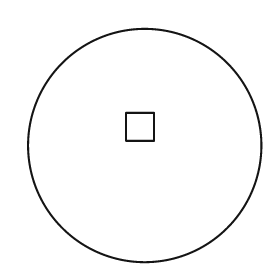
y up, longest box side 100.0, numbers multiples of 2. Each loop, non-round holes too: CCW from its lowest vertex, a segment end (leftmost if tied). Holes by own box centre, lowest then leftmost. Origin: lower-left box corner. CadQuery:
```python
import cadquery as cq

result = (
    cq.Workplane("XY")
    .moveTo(50.0, 50.0)
    .circle(50.0)
    .moveTo(42.0, 52.0)
    .lineTo(54.0, 52.0)
    .lineTo(54.0, 64.0)
    .lineTo(42.0, 64.0)
    .close()
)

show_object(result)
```